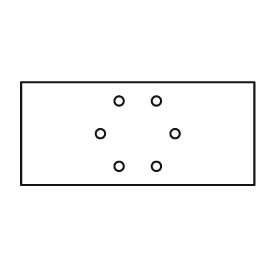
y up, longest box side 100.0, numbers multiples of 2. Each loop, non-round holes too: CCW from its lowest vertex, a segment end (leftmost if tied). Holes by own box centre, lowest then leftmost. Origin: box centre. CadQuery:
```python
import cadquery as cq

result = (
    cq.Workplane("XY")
    .moveTo(-50.0, -22.0)
    .lineTo(50.0, -22.0)
    .lineTo(50.0, 22.0)
    .lineTo(-50.0, 22.0)
    .close()
    .moveTo(-8.0, -14.0)
    .circle(2.0)
    .moveTo(8.0, -14.0)
    .circle(2.0)
    .moveTo(-16.0, 0.0)
    .circle(2.0)
    .moveTo(16.0, 0.0)
    .circle(2.0)
    .moveTo(-8.0, 14.0)
    .circle(2.0)
    .moveTo(8.0, 14.0)
    .circle(2.0)
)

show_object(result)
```